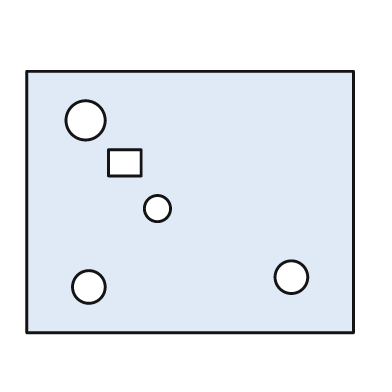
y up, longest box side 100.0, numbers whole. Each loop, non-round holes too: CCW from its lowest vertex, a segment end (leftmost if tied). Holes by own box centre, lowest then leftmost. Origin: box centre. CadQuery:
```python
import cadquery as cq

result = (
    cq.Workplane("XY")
    .moveTo(-50.0, -40.0)
    .lineTo(50.0, -40.0)
    .lineTo(50.0, 40.0)
    .lineTo(-50.0, 40.0)
    .close()
    .moveTo(-31.0, -26.0)
    .circle(5.0)
    .moveTo(31.0, -23.0)
    .circle(5.0)
    .moveTo(-10.0, -2.0)
    .circle(4.0)
    .moveTo(-25.0, 8.0)
    .lineTo(-15.0, 8.0)
    .lineTo(-15.0, 16.0)
    .lineTo(-25.0, 16.0)
    .close()
    .moveTo(-32.0, 25.0)
    .circle(6.0)
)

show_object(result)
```